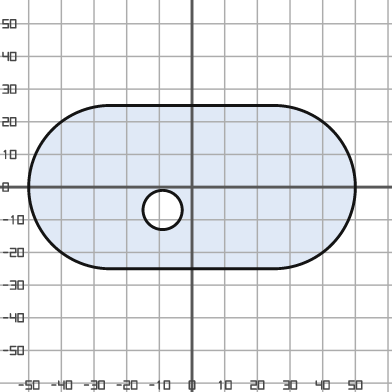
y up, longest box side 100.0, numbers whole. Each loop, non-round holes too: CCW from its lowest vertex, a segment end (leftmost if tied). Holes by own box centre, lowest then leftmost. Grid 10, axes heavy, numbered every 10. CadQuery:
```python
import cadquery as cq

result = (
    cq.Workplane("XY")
    .moveTo(-25.0, -25.0)
    .lineTo(25.0, -25.0)
    .threePointArc((50.0, 0.0), (25.0, 25.0))
    .lineTo(-25.0, 25.0)
    .threePointArc((-50.0, 0.0), (-25.0, -25.0))
    .close()
    .moveTo(-9.0, -7.0)
    .circle(6.0)
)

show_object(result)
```